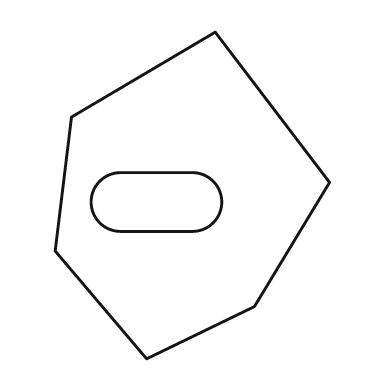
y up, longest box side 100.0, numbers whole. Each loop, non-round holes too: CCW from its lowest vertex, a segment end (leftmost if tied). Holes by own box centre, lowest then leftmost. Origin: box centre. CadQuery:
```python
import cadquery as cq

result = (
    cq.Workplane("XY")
    .moveTo(-14.0, -50.0)
    .lineTo(19.0, -34.0)
    .lineTo(42.0, 4.0)
    .lineTo(7.0, 50.0)
    .lineTo(-37.0, 24.0)
    .lineTo(-42.0, -17.0)
    .close()
    .moveTo(-22.0, -11.0)
    .lineTo(0.0, -11.0)
    .threePointArc((9.0, -2.0), (0.0, 7.0))
    .lineTo(-22.0, 7.0)
    .threePointArc((-31.0, -2.0), (-22.0, -11.0))
    .close()
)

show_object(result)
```